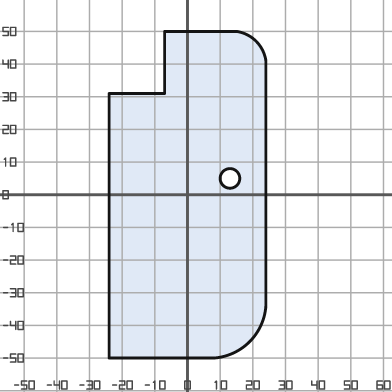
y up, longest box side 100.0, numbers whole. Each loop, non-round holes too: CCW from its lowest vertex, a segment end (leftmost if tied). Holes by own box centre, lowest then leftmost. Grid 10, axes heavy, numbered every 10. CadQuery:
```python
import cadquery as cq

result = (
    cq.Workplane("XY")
    .moveTo(-24.0, -50.0)
    .lineTo(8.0, -50.0)
    .threePointArc((19.0, -45.0), (24.0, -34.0))
    .lineTo(24.0, 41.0)
    .threePointArc((21.0, 47.0), (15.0, 50.0))
    .lineTo(-7.0, 50.0)
    .lineTo(-7.0, 31.0)
    .lineTo(-24.0, 31.0)
    .close()
    .moveTo(13.0, 5.0)
    .circle(3.0)
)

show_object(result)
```